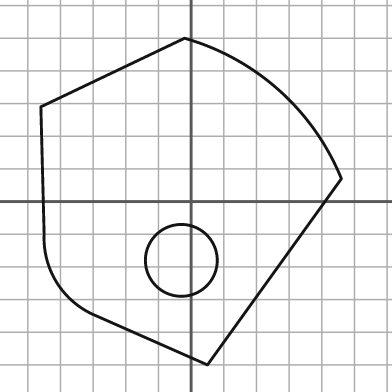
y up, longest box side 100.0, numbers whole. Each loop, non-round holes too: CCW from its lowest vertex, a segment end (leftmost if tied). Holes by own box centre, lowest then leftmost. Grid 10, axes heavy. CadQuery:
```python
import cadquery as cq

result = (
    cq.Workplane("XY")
    .moveTo(5.0, -50.0)
    .lineTo(46.0, 7.0)
    .threePointArc((27.0, 34.0), (-2.0, 50.0))
    .lineTo(-46.0, 29.0)
    .lineTo(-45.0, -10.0)
    .threePointArc((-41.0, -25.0), (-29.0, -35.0))
    .close()
    .moveTo(-3.0, -18.0)
    .circle(11.0)
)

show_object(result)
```